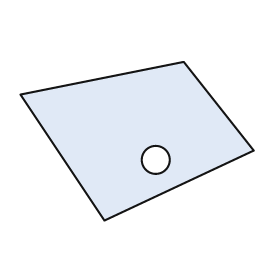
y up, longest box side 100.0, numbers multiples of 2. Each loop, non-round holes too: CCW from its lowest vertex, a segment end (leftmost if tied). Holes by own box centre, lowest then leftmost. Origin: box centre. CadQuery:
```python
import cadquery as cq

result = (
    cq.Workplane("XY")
    .moveTo(-14.0, -34.0)
    .lineTo(50.0, -4.0)
    .lineTo(20.0, 34.0)
    .lineTo(-50.0, 20.0)
    .close()
    .moveTo(8.0, -8.0)
    .circle(6.0)
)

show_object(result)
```